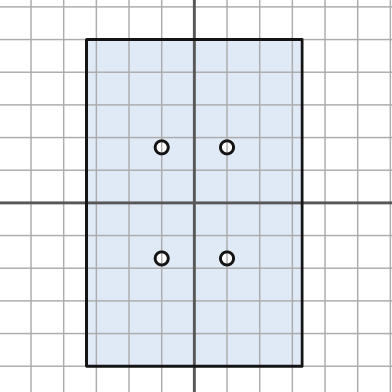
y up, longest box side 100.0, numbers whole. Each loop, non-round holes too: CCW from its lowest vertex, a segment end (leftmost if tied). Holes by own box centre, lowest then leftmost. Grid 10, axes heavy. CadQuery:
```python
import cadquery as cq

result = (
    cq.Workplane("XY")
    .moveTo(-33.0, -50.0)
    .lineTo(33.0, -50.0)
    .lineTo(33.0, 50.0)
    .lineTo(-33.0, 50.0)
    .close()
    .moveTo(-10.0, -17.0)
    .circle(2.0)
    .moveTo(10.0, -17.0)
    .circle(2.0)
    .moveTo(-10.0, 17.0)
    .circle(2.0)
    .moveTo(10.0, 17.0)
    .circle(2.0)
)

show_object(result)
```